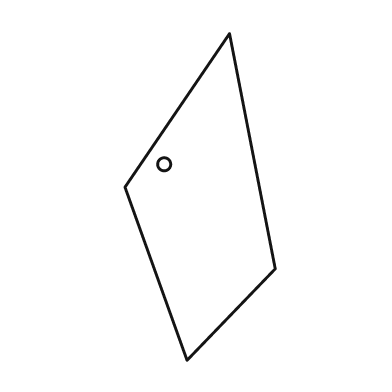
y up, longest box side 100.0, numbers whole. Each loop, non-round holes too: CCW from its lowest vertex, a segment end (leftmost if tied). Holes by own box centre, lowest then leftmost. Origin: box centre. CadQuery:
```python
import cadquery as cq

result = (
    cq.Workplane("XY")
    .moveTo(-4.0, -50.0)
    .lineTo(23.0, -22.0)
    .lineTo(9.0, 50.0)
    .lineTo(-23.0, 3.0)
    .close()
    .moveTo(-11.0, 10.0)
    .circle(2.0)
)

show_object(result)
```